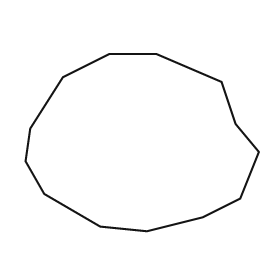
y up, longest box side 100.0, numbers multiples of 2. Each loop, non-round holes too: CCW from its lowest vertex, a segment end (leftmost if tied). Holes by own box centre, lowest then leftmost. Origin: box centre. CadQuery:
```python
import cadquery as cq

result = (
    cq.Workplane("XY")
    .moveTo(2.0, -38.0)
    .lineTo(26.0, -32.0)
    .lineTo(42.0, -24.0)
    .lineTo(50.0, -4.0)
    .lineTo(40.0, 8.0)
    .lineTo(34.0, 26.0)
    .lineTo(6.0, 38.0)
    .lineTo(-14.0, 38.0)
    .lineTo(-34.0, 28.0)
    .lineTo(-48.0, 6.0)
    .lineTo(-50.0, -8.0)
    .lineTo(-42.0, -22.0)
    .lineTo(-18.0, -36.0)
    .close()
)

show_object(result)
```